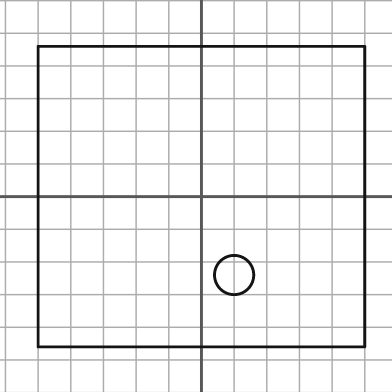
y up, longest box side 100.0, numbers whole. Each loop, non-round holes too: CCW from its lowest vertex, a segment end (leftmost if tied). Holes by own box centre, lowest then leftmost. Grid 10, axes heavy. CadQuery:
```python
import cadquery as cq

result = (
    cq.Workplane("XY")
    .moveTo(-50.0, -46.0)
    .lineTo(50.0, -46.0)
    .lineTo(50.0, 46.0)
    .lineTo(-50.0, 46.0)
    .close()
    .moveTo(10.0, -24.0)
    .circle(6.0)
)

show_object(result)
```